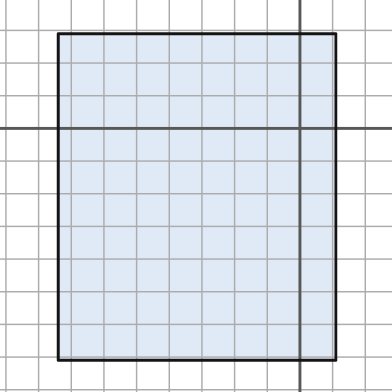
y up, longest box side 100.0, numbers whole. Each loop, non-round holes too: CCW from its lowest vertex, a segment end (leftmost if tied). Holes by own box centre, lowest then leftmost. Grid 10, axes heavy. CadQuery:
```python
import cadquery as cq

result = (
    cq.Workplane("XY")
    .moveTo(-74.0, -71.0)
    .lineTo(11.0, -71.0)
    .lineTo(11.0, 29.0)
    .lineTo(-74.0, 29.0)
    .close()
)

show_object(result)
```